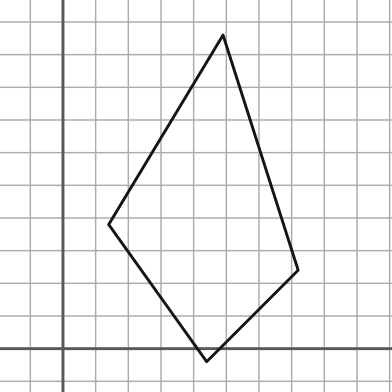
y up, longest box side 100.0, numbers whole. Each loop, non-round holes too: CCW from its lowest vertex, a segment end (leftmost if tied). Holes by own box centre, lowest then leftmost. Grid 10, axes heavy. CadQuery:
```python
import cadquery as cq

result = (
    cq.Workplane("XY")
    .moveTo(44.0, -4.0)
    .lineTo(72.0, 24.0)
    .lineTo(49.0, 96.0)
    .lineTo(14.0, 38.0)
    .close()
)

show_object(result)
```